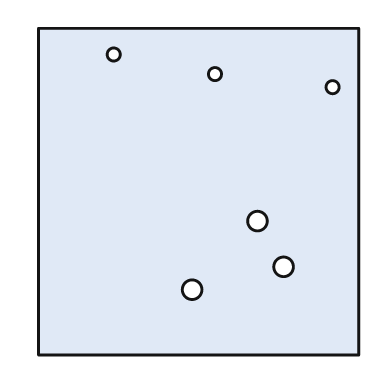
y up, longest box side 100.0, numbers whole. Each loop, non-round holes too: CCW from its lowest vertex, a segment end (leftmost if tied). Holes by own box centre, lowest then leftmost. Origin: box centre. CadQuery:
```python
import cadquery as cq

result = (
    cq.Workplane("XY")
    .moveTo(-49.0, -50.0)
    .lineTo(49.0, -50.0)
    .lineTo(49.0, 50.0)
    .lineTo(-49.0, 50.0)
    .close()
    .moveTo(-2.0, -30.0)
    .circle(3.0)
    .moveTo(26.0, -23.0)
    .circle(3.0)
    .moveTo(18.0, -9.0)
    .circle(3.0)
    .moveTo(41.0, 32.0)
    .circle(2.0)
    .moveTo(5.0, 36.0)
    .circle(2.0)
    .moveTo(-26.0, 42.0)
    .circle(2.0)
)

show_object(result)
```